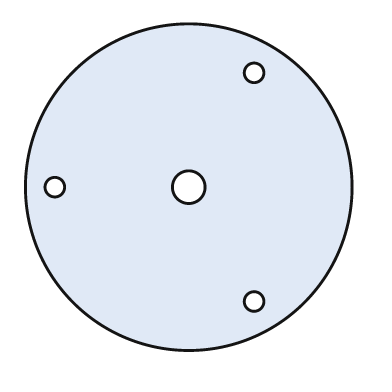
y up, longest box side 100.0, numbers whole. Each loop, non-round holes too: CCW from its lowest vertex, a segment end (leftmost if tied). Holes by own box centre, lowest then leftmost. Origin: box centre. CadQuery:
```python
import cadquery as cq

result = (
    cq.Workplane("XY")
    .moveTo(0.0, 0.0)
    .circle(50.0)
    .moveTo(20.0, -35.0)
    .circle(3.0)
    .moveTo(-41.0, 0.0)
    .circle(3.0)
    .moveTo(0.0, 0.0)
    .circle(5.0)
    .moveTo(20.0, 35.0)
    .circle(3.0)
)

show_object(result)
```